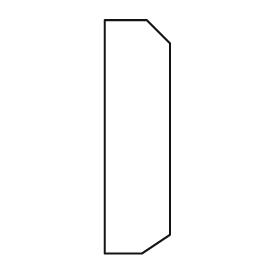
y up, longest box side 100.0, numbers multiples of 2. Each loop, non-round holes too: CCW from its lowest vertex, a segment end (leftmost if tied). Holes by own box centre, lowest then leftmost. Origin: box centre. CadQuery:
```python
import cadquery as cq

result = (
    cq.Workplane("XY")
    .moveTo(-14.0, -50.0)
    .lineTo(2.0, -50.0)
    .lineTo(14.0, -42.0)
    .lineTo(14.0, 40.0)
    .lineTo(4.0, 50.0)
    .lineTo(-14.0, 50.0)
    .close()
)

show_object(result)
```